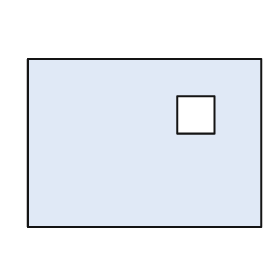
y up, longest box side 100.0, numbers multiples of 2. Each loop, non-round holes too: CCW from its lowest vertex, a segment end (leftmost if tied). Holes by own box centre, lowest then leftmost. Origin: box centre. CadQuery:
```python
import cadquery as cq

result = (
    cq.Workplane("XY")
    .moveTo(-50.0, -36.0)
    .lineTo(50.0, -36.0)
    .lineTo(50.0, 36.0)
    .lineTo(-50.0, 36.0)
    .close()
    .moveTo(14.0, 4.0)
    .lineTo(30.0, 4.0)
    .lineTo(30.0, 20.0)
    .lineTo(14.0, 20.0)
    .close()
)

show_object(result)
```